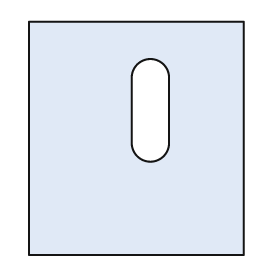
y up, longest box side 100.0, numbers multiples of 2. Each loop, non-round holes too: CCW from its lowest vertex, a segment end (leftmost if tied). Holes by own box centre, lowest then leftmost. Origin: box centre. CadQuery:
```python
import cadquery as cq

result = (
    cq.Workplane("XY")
    .moveTo(-46.0, -50.0)
    .lineTo(46.0, -50.0)
    .lineTo(46.0, 50.0)
    .lineTo(-46.0, 50.0)
    .close()
    .moveTo(-2.0, -2.0)
    .threePointArc((6.0, -10.0), (14.0, -2.0))
    .lineTo(14.0, 26.0)
    .threePointArc((6.0, 34.0), (-2.0, 26.0))
    .close()
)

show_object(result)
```